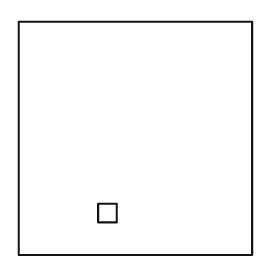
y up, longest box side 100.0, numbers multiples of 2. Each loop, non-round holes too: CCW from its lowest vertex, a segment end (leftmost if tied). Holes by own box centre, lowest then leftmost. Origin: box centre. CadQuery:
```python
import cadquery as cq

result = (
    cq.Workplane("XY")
    .moveTo(-50.0, -50.0)
    .lineTo(50.0, -50.0)
    .lineTo(50.0, 50.0)
    .lineTo(-50.0, 50.0)
    .close()
    .moveTo(-16.0, -36.0)
    .lineTo(-8.0, -36.0)
    .lineTo(-8.0, -28.0)
    .lineTo(-16.0, -28.0)
    .close()
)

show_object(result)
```